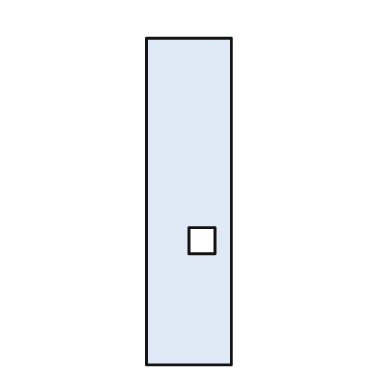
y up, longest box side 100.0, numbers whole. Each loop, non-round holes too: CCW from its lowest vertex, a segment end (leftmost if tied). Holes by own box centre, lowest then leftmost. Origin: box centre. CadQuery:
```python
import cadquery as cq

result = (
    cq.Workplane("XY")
    .moveTo(-13.0, -50.0)
    .lineTo(13.0, -50.0)
    .lineTo(13.0, 50.0)
    .lineTo(-13.0, 50.0)
    .close()
    .moveTo(0.0, -16.0)
    .lineTo(8.0, -16.0)
    .lineTo(8.0, -8.0)
    .lineTo(0.0, -8.0)
    .close()
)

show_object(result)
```